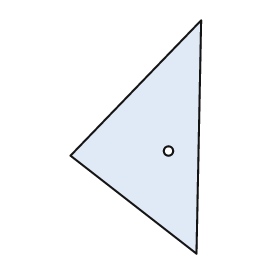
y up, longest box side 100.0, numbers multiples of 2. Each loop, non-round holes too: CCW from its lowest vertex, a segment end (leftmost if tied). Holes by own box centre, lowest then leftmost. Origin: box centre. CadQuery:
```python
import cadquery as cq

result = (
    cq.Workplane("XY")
    .moveTo(26.0, -50.0)
    .lineTo(28.0, 50.0)
    .lineTo(-28.0, -8.0)
    .close()
    .moveTo(14.0, -6.0)
    .circle(2.0)
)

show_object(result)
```